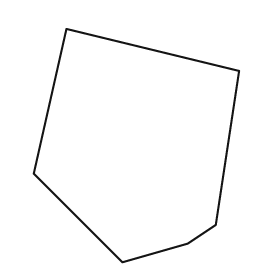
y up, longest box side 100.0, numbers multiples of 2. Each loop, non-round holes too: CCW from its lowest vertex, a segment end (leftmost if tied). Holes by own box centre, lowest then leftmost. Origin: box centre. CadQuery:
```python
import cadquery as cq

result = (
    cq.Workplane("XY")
    .moveTo(-6.0, -50.0)
    .lineTo(22.0, -42.0)
    .lineTo(34.0, -34.0)
    .lineTo(44.0, 32.0)
    .lineTo(-30.0, 50.0)
    .lineTo(-44.0, -12.0)
    .close()
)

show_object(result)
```